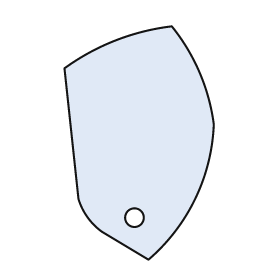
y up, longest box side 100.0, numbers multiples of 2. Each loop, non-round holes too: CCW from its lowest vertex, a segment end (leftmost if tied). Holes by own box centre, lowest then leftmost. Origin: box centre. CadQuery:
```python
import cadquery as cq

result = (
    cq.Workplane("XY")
    .moveTo(4.0, -50.0)
    .threePointArc((24.0, -24.0), (32.0, 8.0))
    .threePointArc((26.0, 30.0), (14.0, 50.0))
    .threePointArc((-10.0, 44.0), (-32.0, 32.0))
    .lineTo(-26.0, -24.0)
    .threePointArc((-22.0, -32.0), (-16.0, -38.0))
    .close()
    .moveTo(-2.0, -32.0)
    .circle(4.0)
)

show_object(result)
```